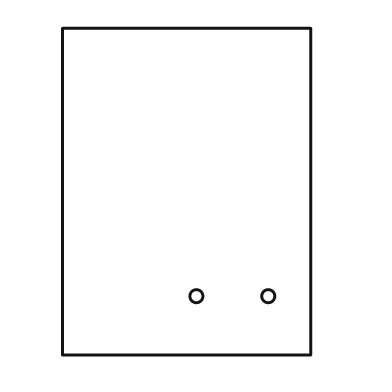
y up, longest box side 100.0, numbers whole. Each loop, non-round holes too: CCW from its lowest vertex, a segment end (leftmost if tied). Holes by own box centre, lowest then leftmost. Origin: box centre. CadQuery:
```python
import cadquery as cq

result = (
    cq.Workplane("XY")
    .moveTo(-38.0, -50.0)
    .lineTo(38.0, -50.0)
    .lineTo(38.0, 50.0)
    .lineTo(-38.0, 50.0)
    .close()
    .moveTo(3.0, -32.0)
    .circle(2.0)
    .moveTo(25.0, -32.0)
    .circle(2.0)
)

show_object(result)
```